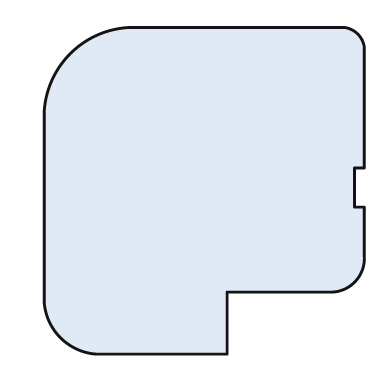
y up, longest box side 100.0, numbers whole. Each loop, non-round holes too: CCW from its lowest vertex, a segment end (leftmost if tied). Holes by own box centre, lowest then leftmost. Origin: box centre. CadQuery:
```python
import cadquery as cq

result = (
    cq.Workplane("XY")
    .moveTo(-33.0, -50.0)
    .lineTo(7.0, -50.0)
    .lineTo(7.0, -31.0)
    .lineTo(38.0, -31.0)
    .threePointArc((46.0, -28.0), (49.0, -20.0))
    .lineTo(49.0, -5.0)
    .lineTo(46.0, -5.0)
    .lineTo(46.0, 7.0)
    .lineTo(49.0, 7.0)
    .lineTo(49.0, 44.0)
    .threePointArc((47.0, 48.0), (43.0, 50.0))
    .lineTo(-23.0, 50.0)
    .threePointArc((-41.0, 42.0), (-49.0, 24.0))
    .lineTo(-49.0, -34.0)
    .threePointArc((-44.0, -45.0), (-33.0, -50.0))
    .close()
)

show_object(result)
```